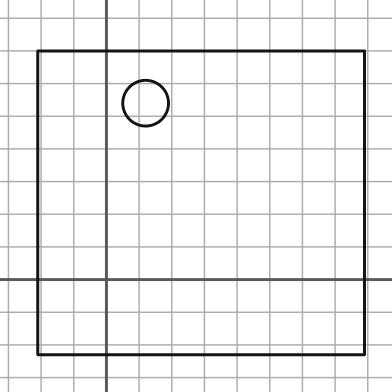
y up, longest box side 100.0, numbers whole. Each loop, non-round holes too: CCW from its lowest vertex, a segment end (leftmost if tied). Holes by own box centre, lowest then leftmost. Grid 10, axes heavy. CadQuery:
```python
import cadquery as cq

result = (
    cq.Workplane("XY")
    .moveTo(-21.0, -23.0)
    .lineTo(79.0, -23.0)
    .lineTo(79.0, 70.0)
    .lineTo(-21.0, 70.0)
    .close()
    .moveTo(12.0, 54.0)
    .circle(7.0)
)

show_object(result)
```